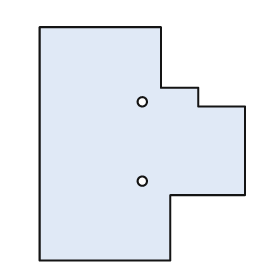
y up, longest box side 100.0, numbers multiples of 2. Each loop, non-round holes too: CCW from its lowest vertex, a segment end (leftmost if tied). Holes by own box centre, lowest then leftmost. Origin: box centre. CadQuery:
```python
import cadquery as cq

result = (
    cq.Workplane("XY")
    .moveTo(-44.0, -50.0)
    .lineTo(12.0, -50.0)
    .lineTo(12.0, -22.0)
    .lineTo(44.0, -22.0)
    .lineTo(44.0, 16.0)
    .lineTo(24.0, 16.0)
    .lineTo(24.0, 24.0)
    .lineTo(8.0, 24.0)
    .lineTo(8.0, 50.0)
    .lineTo(-44.0, 50.0)
    .close()
    .moveTo(0.0, -16.0)
    .circle(2.0)
    .moveTo(0.0, 18.0)
    .circle(2.0)
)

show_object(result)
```